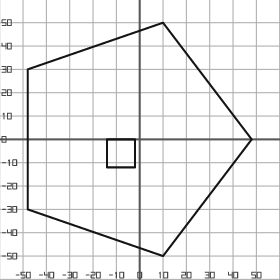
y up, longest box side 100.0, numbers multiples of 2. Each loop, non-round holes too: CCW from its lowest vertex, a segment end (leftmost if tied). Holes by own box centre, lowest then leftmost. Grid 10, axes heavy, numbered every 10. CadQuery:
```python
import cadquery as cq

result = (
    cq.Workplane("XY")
    .moveTo(10.0, -50.0)
    .lineTo(48.0, 0.0)
    .lineTo(10.0, 50.0)
    .lineTo(-48.0, 30.0)
    .lineTo(-48.0, -30.0)
    .close()
    .moveTo(-14.0, -12.0)
    .lineTo(-2.0, -12.0)
    .lineTo(-2.0, 0.0)
    .lineTo(-14.0, 0.0)
    .close()
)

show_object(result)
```